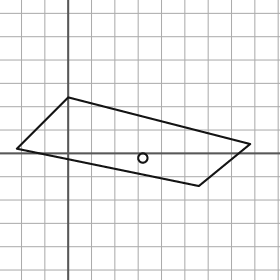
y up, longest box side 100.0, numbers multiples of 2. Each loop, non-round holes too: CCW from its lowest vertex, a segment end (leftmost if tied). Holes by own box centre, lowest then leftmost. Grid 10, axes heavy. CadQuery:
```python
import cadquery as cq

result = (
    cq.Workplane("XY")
    .moveTo(56.0, -14.0)
    .lineTo(78.0, 4.0)
    .lineTo(0.0, 24.0)
    .lineTo(-22.0, 2.0)
    .close()
    .moveTo(32.0, -2.0)
    .circle(2.0)
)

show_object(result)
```